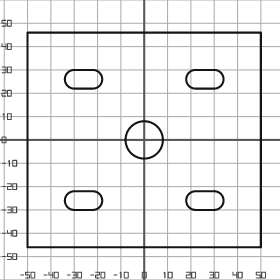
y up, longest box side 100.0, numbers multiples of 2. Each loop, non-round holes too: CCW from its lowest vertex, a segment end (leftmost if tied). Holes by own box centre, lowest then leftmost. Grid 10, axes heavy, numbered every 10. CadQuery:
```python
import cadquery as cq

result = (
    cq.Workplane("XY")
    .moveTo(-50.0, -46.0)
    .lineTo(50.0, -46.0)
    .lineTo(50.0, 46.0)
    .lineTo(-50.0, 46.0)
    .close()
    .moveTo(-30.0, -30.0)
    .lineTo(-22.0, -30.0)
    .threePointArc((-18.0, -26.0), (-22.0, -22.0))
    .lineTo(-30.0, -22.0)
    .threePointArc((-34.0, -26.0), (-30.0, -30.0))
    .close()
    .moveTo(22.0, -30.0)
    .lineTo(30.0, -30.0)
    .threePointArc((34.0, -26.0), (30.0, -22.0))
    .lineTo(22.0, -22.0)
    .threePointArc((18.0, -26.0), (22.0, -30.0))
    .close()
    .moveTo(0.0, 0.0)
    .circle(8.0)
    .moveTo(-30.0, 22.0)
    .lineTo(-22.0, 22.0)
    .threePointArc((-18.0, 26.0), (-22.0, 30.0))
    .lineTo(-30.0, 30.0)
    .threePointArc((-34.0, 26.0), (-30.0, 22.0))
    .close()
    .moveTo(22.0, 22.0)
    .lineTo(30.0, 22.0)
    .threePointArc((34.0, 26.0), (30.0, 30.0))
    .lineTo(22.0, 30.0)
    .threePointArc((18.0, 26.0), (22.0, 22.0))
    .close()
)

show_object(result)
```